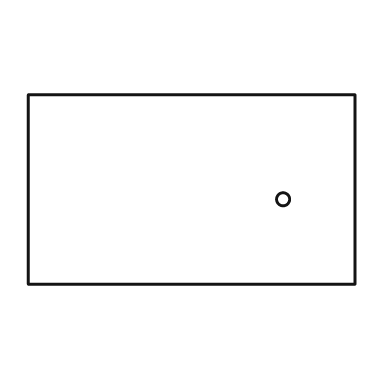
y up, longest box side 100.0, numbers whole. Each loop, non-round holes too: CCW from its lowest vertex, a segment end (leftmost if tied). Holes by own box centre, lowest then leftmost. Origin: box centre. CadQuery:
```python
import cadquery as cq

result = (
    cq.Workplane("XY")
    .moveTo(-50.0, -29.0)
    .lineTo(50.0, -29.0)
    .lineTo(50.0, 29.0)
    .lineTo(-50.0, 29.0)
    .close()
    .moveTo(28.0, -3.0)
    .circle(2.0)
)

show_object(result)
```